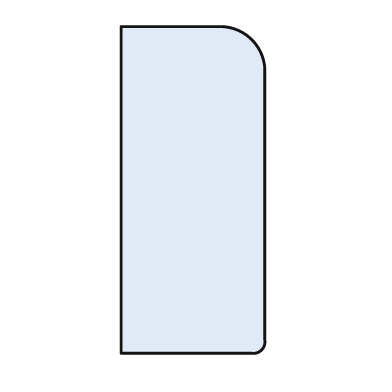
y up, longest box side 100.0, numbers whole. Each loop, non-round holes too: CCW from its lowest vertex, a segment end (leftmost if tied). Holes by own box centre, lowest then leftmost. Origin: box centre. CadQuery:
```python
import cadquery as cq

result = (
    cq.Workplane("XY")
    .moveTo(-22.0, -50.0)
    .lineTo(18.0, -50.0)
    .threePointArc((21.0, -49.0), (22.0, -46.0))
    .lineTo(22.0, 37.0)
    .threePointArc((18.0, 46.0), (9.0, 50.0))
    .lineTo(-22.0, 50.0)
    .close()
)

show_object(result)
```